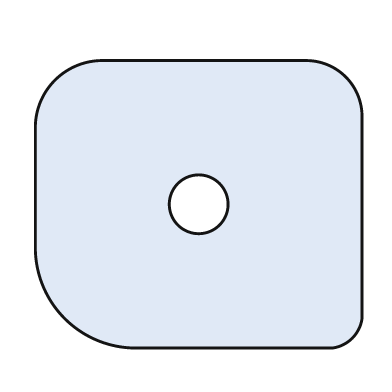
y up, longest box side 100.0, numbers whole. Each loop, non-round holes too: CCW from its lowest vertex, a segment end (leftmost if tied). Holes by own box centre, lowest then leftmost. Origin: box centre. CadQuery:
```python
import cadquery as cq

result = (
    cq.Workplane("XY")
    .moveTo(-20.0, -44.0)
    .lineTo(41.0, -44.0)
    .threePointArc((47.0, -41.0), (50.0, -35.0))
    .lineTo(50.0, 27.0)
    .threePointArc((45.0, 39.0), (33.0, 44.0))
    .lineTo(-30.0, 44.0)
    .threePointArc((-44.0, 38.0), (-50.0, 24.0))
    .lineTo(-50.0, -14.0)
    .threePointArc((-41.0, -35.0), (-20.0, -44.0))
    .close()
    .moveTo(0.0, 0.0)
    .circle(9.0)
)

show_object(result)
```